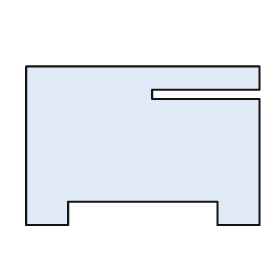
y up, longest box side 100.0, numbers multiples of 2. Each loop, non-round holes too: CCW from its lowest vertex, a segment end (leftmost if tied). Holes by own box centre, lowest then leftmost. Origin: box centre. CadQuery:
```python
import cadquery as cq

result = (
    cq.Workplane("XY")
    .moveTo(-50.0, -34.0)
    .lineTo(-32.0, -34.0)
    .lineTo(-32.0, -24.0)
    .lineTo(32.0, -24.0)
    .lineTo(32.0, -34.0)
    .lineTo(50.0, -34.0)
    .lineTo(50.0, 20.0)
    .lineTo(4.0, 20.0)
    .lineTo(4.0, 24.0)
    .lineTo(50.0, 24.0)
    .lineTo(50.0, 34.0)
    .lineTo(-50.0, 34.0)
    .close()
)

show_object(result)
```